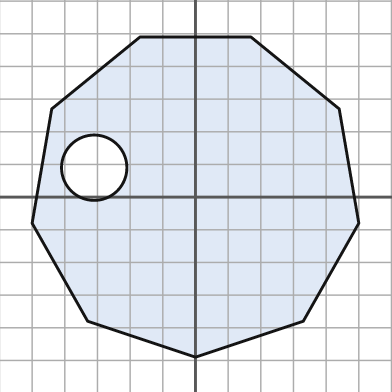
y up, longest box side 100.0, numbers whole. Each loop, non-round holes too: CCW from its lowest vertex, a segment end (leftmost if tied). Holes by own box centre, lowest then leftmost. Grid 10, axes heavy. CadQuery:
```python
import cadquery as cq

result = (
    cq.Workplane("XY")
    .moveTo(0.0, -49.0)
    .lineTo(33.0, -38.0)
    .lineTo(50.0, -8.0)
    .lineTo(44.0, 27.0)
    .lineTo(17.0, 49.0)
    .lineTo(-17.0, 49.0)
    .lineTo(-44.0, 27.0)
    .lineTo(-50.0, -8.0)
    .lineTo(-33.0, -38.0)
    .close()
    .moveTo(-31.0, 9.0)
    .circle(10.0)
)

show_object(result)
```